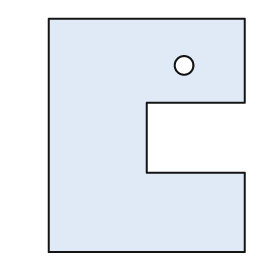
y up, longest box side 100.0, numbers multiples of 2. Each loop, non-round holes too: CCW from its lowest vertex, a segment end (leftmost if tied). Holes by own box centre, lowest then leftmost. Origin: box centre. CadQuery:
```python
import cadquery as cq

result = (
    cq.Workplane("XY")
    .moveTo(-42.0, -50.0)
    .lineTo(42.0, -50.0)
    .lineTo(42.0, -16.0)
    .lineTo(0.0, -16.0)
    .lineTo(0.0, 14.0)
    .lineTo(42.0, 14.0)
    .lineTo(42.0, 50.0)
    .lineTo(-42.0, 50.0)
    .close()
    .moveTo(16.0, 30.0)
    .circle(4.0)
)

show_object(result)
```